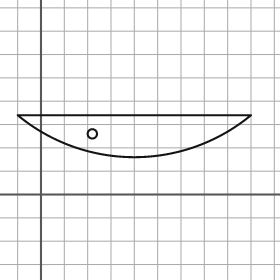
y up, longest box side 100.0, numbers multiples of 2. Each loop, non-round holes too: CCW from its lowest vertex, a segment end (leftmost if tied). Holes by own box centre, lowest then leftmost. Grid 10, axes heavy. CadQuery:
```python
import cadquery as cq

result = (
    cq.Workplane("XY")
    .moveTo(-10.0, 34.0)
    .threePointArc((40.0, 16.0), (90.0, 34.0))
    .close()
    .moveTo(22.0, 26.0)
    .circle(2.0)
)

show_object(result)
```